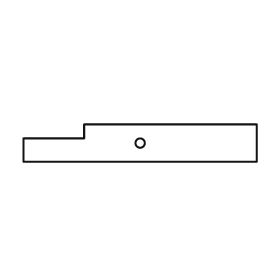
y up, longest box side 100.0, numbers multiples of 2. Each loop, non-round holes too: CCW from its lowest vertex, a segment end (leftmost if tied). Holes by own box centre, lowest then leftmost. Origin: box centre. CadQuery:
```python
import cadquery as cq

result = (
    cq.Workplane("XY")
    .moveTo(-50.0, -8.0)
    .lineTo(50.0, -8.0)
    .lineTo(50.0, 8.0)
    .lineTo(-24.0, 8.0)
    .lineTo(-24.0, 2.0)
    .lineTo(-50.0, 2.0)
    .close()
    .moveTo(0.0, 0.0)
    .circle(2.0)
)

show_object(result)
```